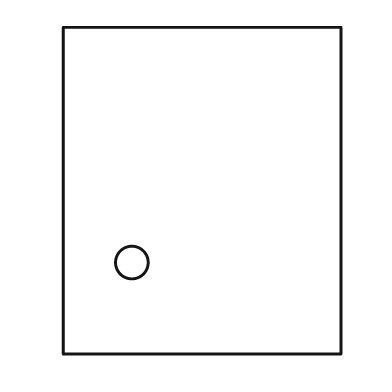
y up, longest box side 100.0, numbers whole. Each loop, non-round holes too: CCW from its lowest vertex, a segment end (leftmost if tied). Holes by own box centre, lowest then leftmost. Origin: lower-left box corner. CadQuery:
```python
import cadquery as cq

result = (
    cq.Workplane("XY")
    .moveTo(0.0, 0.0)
    .lineTo(85.0, 0.0)
    .lineTo(85.0, 100.0)
    .lineTo(0.0, 100.0)
    .close()
    .moveTo(21.0, 28.0)
    .circle(5.0)
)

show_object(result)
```